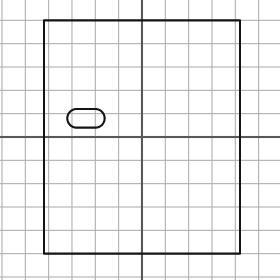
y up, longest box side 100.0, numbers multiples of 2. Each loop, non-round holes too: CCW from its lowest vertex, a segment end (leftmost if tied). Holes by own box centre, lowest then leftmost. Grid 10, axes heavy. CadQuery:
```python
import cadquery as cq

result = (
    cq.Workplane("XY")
    .moveTo(-42.0, -50.0)
    .lineTo(42.0, -50.0)
    .lineTo(42.0, 50.0)
    .lineTo(-42.0, 50.0)
    .close()
    .moveTo(-28.0, 4.0)
    .lineTo(-20.0, 4.0)
    .threePointArc((-16.0, 8.0), (-20.0, 12.0))
    .lineTo(-28.0, 12.0)
    .threePointArc((-32.0, 8.0), (-28.0, 4.0))
    .close()
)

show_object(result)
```